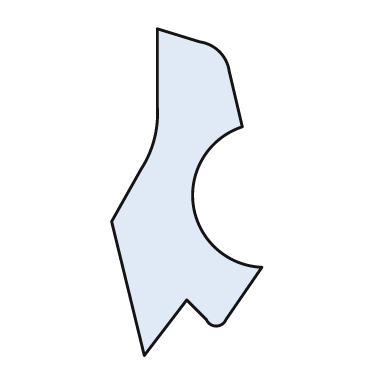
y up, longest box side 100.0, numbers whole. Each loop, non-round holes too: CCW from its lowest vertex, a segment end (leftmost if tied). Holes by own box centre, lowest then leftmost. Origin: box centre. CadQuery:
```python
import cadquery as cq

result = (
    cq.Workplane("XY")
    .moveTo(-13.0, -50.0)
    .lineTo(0.0, -33.0)
    .lineTo(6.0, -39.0)
    .threePointArc((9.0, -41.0), (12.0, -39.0))
    .lineTo(23.0, -23.0)
    .threePointArc((2.0, -4.0), (17.0, 20.0))
    .lineTo(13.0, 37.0)
    .threePointArc((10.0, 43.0), (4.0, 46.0))
    .lineTo(-9.0, 50.0)
    .lineTo(-9.0, 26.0)
    .threePointArc((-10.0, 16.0), (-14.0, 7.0))
    .lineTo(-23.0, -9.0)
    .close()
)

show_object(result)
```